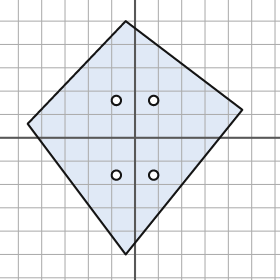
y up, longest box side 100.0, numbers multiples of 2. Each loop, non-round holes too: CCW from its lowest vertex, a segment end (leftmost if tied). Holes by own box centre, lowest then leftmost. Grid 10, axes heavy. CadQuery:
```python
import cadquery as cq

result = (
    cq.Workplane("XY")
    .moveTo(-4.0, -50.0)
    .lineTo(46.0, 12.0)
    .lineTo(-4.0, 50.0)
    .lineTo(-46.0, 6.0)
    .close()
    .moveTo(-8.0, -16.0)
    .circle(2.0)
    .moveTo(8.0, -16.0)
    .circle(2.0)
    .moveTo(-8.0, 16.0)
    .circle(2.0)
    .moveTo(8.0, 16.0)
    .circle(2.0)
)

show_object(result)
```